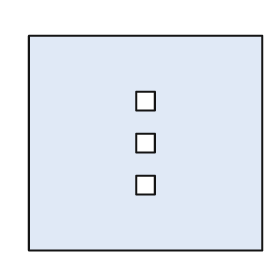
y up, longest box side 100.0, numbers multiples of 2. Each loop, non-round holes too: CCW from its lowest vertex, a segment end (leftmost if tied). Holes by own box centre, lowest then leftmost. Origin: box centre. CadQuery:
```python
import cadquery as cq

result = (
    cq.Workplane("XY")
    .moveTo(-50.0, -46.0)
    .lineTo(50.0, -46.0)
    .lineTo(50.0, 46.0)
    .lineTo(-50.0, 46.0)
    .close()
    .moveTo(-4.0, -22.0)
    .lineTo(4.0, -22.0)
    .lineTo(4.0, -14.0)
    .lineTo(-4.0, -14.0)
    .close()
    .moveTo(-4.0, -4.0)
    .lineTo(4.0, -4.0)
    .lineTo(4.0, 4.0)
    .lineTo(-4.0, 4.0)
    .close()
    .moveTo(-4.0, 14.0)
    .lineTo(4.0, 14.0)
    .lineTo(4.0, 22.0)
    .lineTo(-4.0, 22.0)
    .close()
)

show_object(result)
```